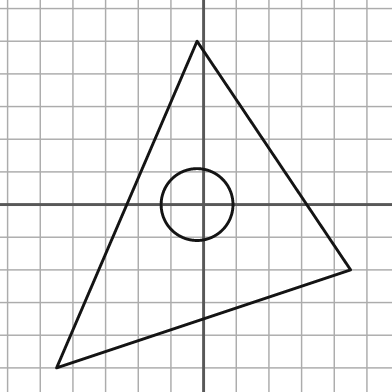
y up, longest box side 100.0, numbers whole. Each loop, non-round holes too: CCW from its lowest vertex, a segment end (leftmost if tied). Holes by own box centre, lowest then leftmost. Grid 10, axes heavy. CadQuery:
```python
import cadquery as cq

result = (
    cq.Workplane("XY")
    .moveTo(-45.0, -50.0)
    .lineTo(45.0, -20.0)
    .lineTo(-2.0, 50.0)
    .close()
    .moveTo(-2.0, 0.0)
    .circle(11.0)
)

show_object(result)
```